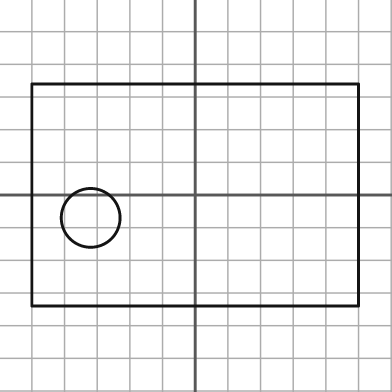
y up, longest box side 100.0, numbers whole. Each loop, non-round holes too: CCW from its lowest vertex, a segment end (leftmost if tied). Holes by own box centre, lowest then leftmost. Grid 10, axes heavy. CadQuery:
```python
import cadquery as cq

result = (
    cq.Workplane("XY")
    .moveTo(-50.0, -34.0)
    .lineTo(50.0, -34.0)
    .lineTo(50.0, 34.0)
    .lineTo(-50.0, 34.0)
    .close()
    .moveTo(-32.0, -7.0)
    .circle(9.0)
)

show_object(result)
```